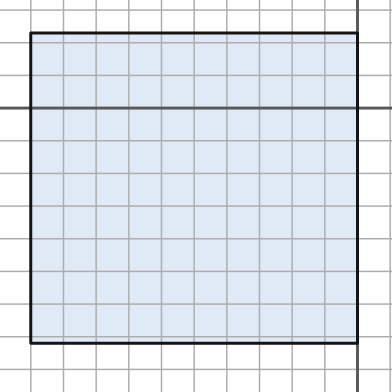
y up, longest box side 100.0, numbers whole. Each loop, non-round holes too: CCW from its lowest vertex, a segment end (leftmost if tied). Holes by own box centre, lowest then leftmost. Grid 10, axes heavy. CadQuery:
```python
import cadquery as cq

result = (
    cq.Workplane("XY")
    .moveTo(-100.0, -72.0)
    .lineTo(0.0, -72.0)
    .lineTo(0.0, 23.0)
    .lineTo(-100.0, 23.0)
    .close()
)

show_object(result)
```